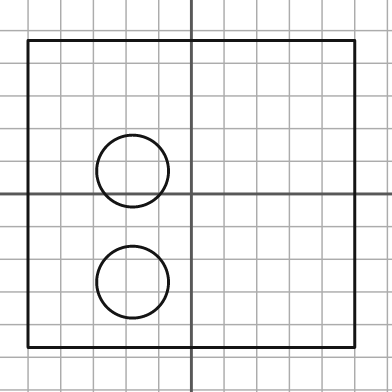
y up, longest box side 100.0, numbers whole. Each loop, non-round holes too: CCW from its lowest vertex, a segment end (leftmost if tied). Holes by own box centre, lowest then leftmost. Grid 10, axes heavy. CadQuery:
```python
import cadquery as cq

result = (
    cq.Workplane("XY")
    .moveTo(-50.0, -47.0)
    .lineTo(50.0, -47.0)
    .lineTo(50.0, 47.0)
    .lineTo(-50.0, 47.0)
    .close()
    .moveTo(-18.0, -27.0)
    .circle(11.0)
    .moveTo(-18.0, 7.0)
    .circle(11.0)
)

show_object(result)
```